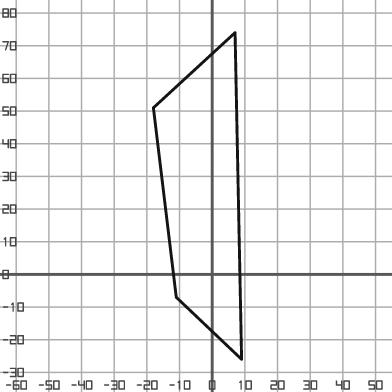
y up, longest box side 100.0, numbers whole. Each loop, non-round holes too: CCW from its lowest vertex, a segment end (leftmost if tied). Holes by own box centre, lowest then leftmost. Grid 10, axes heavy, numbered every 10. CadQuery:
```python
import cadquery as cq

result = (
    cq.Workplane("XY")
    .moveTo(9.0, -26.0)
    .lineTo(7.0, 74.0)
    .lineTo(-18.0, 51.0)
    .lineTo(-11.0, -7.0)
    .close()
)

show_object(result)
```